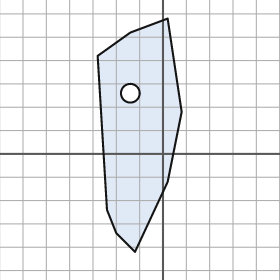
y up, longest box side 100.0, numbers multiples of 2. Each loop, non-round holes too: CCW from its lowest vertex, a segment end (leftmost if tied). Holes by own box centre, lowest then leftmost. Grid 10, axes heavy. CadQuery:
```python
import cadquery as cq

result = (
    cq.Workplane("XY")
    .moveTo(-12.0, -42.0)
    .lineTo(2.0, -12.0)
    .lineTo(8.0, 18.0)
    .lineTo(2.0, 58.0)
    .lineTo(-14.0, 52.0)
    .lineTo(-28.0, 42.0)
    .lineTo(-24.0, -24.0)
    .lineTo(-20.0, -34.0)
    .close()
    .moveTo(-14.0, 26.0)
    .circle(4.0)
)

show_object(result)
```